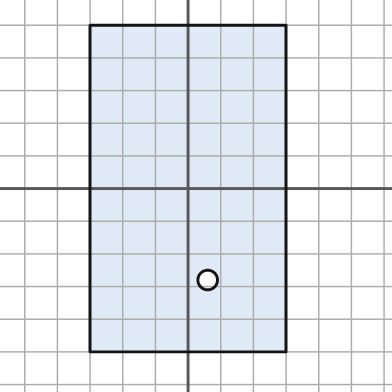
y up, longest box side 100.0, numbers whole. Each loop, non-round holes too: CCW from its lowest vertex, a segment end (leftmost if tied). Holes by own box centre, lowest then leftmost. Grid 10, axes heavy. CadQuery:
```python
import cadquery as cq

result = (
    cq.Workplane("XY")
    .moveTo(-30.0, -50.0)
    .lineTo(30.0, -50.0)
    .lineTo(30.0, 50.0)
    .lineTo(-30.0, 50.0)
    .close()
    .moveTo(6.0, -28.0)
    .circle(3.0)
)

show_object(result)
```